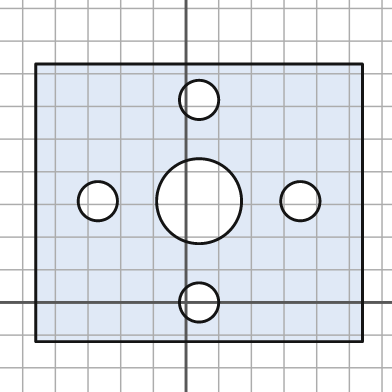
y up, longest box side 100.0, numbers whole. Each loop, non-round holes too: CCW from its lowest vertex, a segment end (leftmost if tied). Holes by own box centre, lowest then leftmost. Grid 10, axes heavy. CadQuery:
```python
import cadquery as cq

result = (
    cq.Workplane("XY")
    .moveTo(-46.0, -12.0)
    .lineTo(54.0, -12.0)
    .lineTo(54.0, 73.0)
    .lineTo(-46.0, 73.0)
    .close()
    .moveTo(4.0, 0.0)
    .circle(6.0)
    .moveTo(-27.0, 31.0)
    .circle(6.0)
    .moveTo(4.0, 31.0)
    .circle(13.0)
    .moveTo(35.0, 31.0)
    .circle(6.0)
    .moveTo(4.0, 62.0)
    .circle(6.0)
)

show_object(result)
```